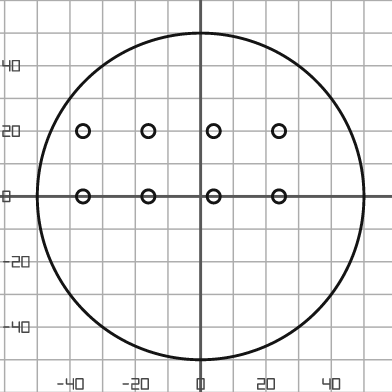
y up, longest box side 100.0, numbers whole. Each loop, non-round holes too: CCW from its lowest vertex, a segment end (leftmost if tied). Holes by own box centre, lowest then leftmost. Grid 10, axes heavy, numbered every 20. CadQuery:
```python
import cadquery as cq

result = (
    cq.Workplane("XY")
    .moveTo(0.0, 0.0)
    .circle(50.0)
    .moveTo(-36.0, 0.0)
    .circle(2.0)
    .moveTo(-16.0, 0.0)
    .circle(2.0)
    .moveTo(4.0, 0.0)
    .circle(2.0)
    .moveTo(24.0, 0.0)
    .circle(2.0)
    .moveTo(-36.0, 20.0)
    .circle(2.0)
    .moveTo(-16.0, 20.0)
    .circle(2.0)
    .moveTo(4.0, 20.0)
    .circle(2.0)
    .moveTo(24.0, 20.0)
    .circle(2.0)
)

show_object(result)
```